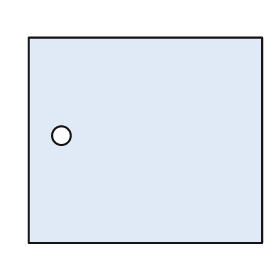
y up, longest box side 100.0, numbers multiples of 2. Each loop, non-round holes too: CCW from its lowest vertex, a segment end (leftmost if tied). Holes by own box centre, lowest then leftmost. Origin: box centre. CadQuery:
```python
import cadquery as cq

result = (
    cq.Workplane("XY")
    .moveTo(-50.0, -44.0)
    .lineTo(50.0, -44.0)
    .lineTo(50.0, 44.0)
    .lineTo(-50.0, 44.0)
    .close()
    .moveTo(-36.0, 2.0)
    .circle(4.0)
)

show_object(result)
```